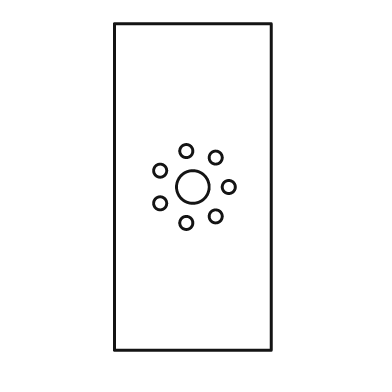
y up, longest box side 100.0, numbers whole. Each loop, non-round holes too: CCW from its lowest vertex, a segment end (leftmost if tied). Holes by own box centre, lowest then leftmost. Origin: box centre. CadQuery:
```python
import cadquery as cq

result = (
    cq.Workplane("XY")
    .moveTo(-24.0, -50.0)
    .lineTo(24.0, -50.0)
    .lineTo(24.0, 50.0)
    .lineTo(-24.0, 50.0)
    .close()
    .moveTo(-2.0, -11.0)
    .circle(2.0)
    .moveTo(7.0, -9.0)
    .circle(2.0)
    .moveTo(-10.0, -5.0)
    .circle(2.0)
    .moveTo(0.0, 0.0)
    .circle(5.0)
    .moveTo(11.0, 0.0)
    .circle(2.0)
    .moveTo(-10.0, 5.0)
    .circle(2.0)
    .moveTo(7.0, 9.0)
    .circle(2.0)
    .moveTo(-2.0, 11.0)
    .circle(2.0)
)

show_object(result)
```